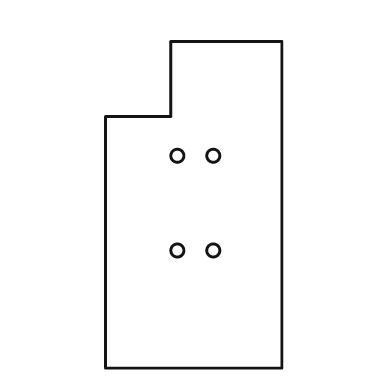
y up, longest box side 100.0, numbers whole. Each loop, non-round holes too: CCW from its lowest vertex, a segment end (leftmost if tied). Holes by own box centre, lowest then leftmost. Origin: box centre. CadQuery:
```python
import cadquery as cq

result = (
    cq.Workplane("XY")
    .moveTo(-27.0, -50.0)
    .lineTo(27.0, -50.0)
    .lineTo(27.0, 50.0)
    .lineTo(-7.0, 50.0)
    .lineTo(-7.0, 27.0)
    .lineTo(-27.0, 27.0)
    .close()
    .moveTo(-5.0, -14.0)
    .circle(2.0)
    .moveTo(6.0, -14.0)
    .circle(2.0)
    .moveTo(-5.0, 15.0)
    .circle(2.0)
    .moveTo(6.0, 15.0)
    .circle(2.0)
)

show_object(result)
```